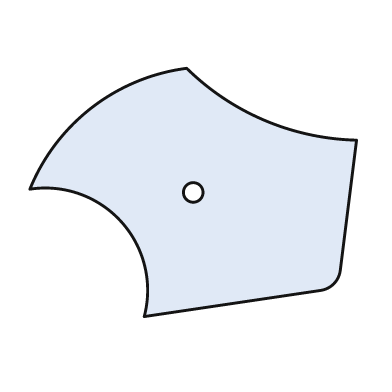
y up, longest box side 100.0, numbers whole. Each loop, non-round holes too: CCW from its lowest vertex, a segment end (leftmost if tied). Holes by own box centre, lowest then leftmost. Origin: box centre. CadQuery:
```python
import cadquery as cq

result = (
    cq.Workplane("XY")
    .moveTo(-15.0, -38.0)
    .lineTo(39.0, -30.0)
    .threePointArc((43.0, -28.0), (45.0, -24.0))
    .lineTo(50.0, 16.0)
    .threePointArc((22.0, 22.0), (-2.0, 38.0))
    .threePointArc((-31.0, 26.0), (-50.0, 1.0))
    .threePointArc((-22.0, -9.0), (-15.0, -38.0))
    .close()
    .moveTo(0.0, 0.0)
    .circle(3.0)
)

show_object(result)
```